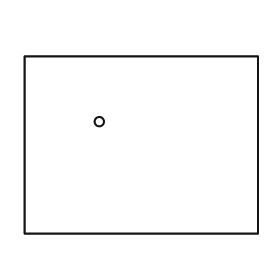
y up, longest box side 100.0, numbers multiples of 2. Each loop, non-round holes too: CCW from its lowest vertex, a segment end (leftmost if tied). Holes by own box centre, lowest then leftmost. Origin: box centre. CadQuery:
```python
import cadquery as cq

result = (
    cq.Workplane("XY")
    .moveTo(-50.0, -38.0)
    .lineTo(50.0, -38.0)
    .lineTo(50.0, 38.0)
    .lineTo(-50.0, 38.0)
    .close()
    .moveTo(-18.0, 10.0)
    .circle(2.0)
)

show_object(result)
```